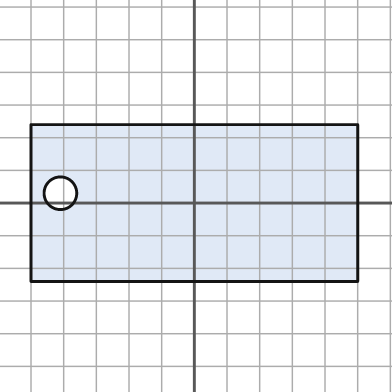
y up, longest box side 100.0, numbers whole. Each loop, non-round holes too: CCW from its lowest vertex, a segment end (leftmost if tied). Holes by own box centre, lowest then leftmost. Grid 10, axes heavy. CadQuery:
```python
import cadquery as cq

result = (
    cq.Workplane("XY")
    .moveTo(-50.0, -24.0)
    .lineTo(50.0, -24.0)
    .lineTo(50.0, 24.0)
    .lineTo(-50.0, 24.0)
    .close()
    .moveTo(-41.0, 3.0)
    .circle(5.0)
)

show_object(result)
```